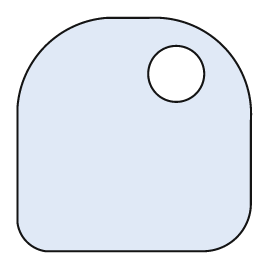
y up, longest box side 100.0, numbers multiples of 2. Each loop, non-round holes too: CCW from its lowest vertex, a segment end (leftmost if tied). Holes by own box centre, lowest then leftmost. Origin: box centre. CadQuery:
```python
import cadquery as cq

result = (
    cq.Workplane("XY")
    .moveTo(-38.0, -50.0)
    .lineTo(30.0, -50.0)
    .threePointArc((44.0, -44.0), (50.0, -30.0))
    .lineTo(50.0, 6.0)
    .threePointArc((38.0, 38.0), (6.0, 50.0))
    .lineTo(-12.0, 50.0)
    .threePointArc((-38.0, 38.0), (-50.0, 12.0))
    .lineTo(-50.0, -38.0)
    .threePointArc((-46.0, -46.0), (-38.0, -50.0))
    .close()
    .moveTo(18.0, 26.0)
    .circle(12.0)
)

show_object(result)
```